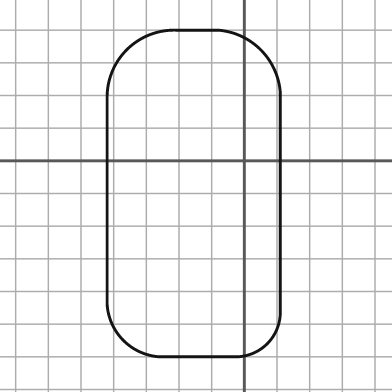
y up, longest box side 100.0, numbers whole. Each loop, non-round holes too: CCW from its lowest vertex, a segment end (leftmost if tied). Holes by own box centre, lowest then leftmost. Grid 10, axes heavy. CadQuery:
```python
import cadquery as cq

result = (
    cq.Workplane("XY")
    .moveTo(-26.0, -60.0)
    .lineTo(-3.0, -60.0)
    .threePointArc((7.0, -56.0), (11.0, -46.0))
    .lineTo(11.0, 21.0)
    .threePointArc((5.0, 34.0), (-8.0, 40.0))
    .lineTo(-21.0, 40.0)
    .threePointArc((-36.0, 34.0), (-42.0, 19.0))
    .lineTo(-42.0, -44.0)
    .threePointArc((-37.0, -55.0), (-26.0, -60.0))
    .close()
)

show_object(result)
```